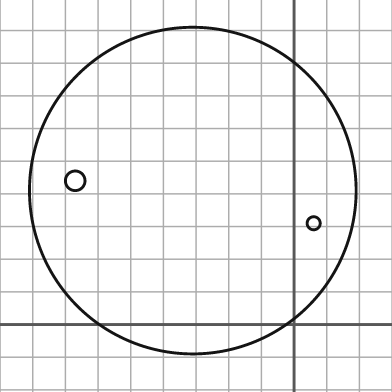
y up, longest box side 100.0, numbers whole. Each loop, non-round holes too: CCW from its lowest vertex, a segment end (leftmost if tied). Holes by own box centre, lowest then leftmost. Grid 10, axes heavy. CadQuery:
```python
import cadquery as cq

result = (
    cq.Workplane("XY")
    .moveTo(-31.0, 41.0)
    .circle(50.0)
    .moveTo(6.0, 31.0)
    .circle(2.0)
    .moveTo(-67.0, 44.0)
    .circle(3.0)
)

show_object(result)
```